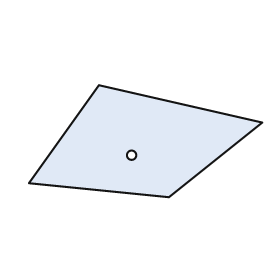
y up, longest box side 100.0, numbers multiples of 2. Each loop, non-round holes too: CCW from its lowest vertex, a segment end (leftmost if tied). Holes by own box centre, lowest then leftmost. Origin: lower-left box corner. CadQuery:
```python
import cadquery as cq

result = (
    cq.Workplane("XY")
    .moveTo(60.0, 0.0)
    .lineTo(100.0, 32.0)
    .lineTo(30.0, 48.0)
    .lineTo(0.0, 6.0)
    .close()
    .moveTo(44.0, 18.0)
    .circle(2.0)
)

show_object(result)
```